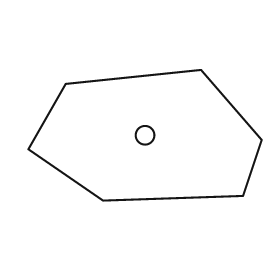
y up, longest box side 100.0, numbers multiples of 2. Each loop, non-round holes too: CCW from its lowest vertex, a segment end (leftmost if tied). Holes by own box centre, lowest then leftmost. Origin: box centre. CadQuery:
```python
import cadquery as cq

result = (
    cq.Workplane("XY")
    .moveTo(-18.0, -28.0)
    .lineTo(42.0, -26.0)
    .lineTo(50.0, -2.0)
    .lineTo(24.0, 28.0)
    .lineTo(-34.0, 22.0)
    .lineTo(-50.0, -6.0)
    .close()
    .moveTo(0.0, 0.0)
    .circle(4.0)
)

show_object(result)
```